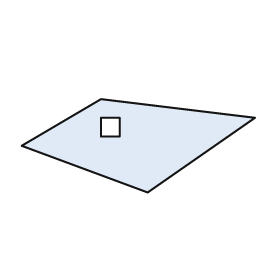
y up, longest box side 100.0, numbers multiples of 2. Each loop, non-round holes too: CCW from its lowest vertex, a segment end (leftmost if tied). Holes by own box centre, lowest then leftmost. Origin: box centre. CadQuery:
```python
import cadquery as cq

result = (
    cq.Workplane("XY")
    .moveTo(4.0, -20.0)
    .lineTo(50.0, 12.0)
    .lineTo(-16.0, 20.0)
    .lineTo(-50.0, 0.0)
    .close()
    .moveTo(-16.0, 4.0)
    .lineTo(-8.0, 4.0)
    .lineTo(-8.0, 12.0)
    .lineTo(-16.0, 12.0)
    .close()
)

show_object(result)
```